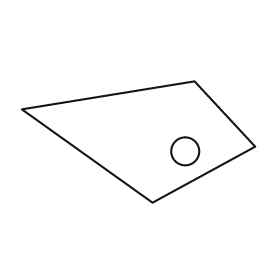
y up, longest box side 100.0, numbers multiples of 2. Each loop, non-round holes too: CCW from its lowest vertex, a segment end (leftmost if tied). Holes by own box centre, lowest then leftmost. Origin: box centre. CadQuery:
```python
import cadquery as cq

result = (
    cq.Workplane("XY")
    .moveTo(6.0, -26.0)
    .lineTo(50.0, -2.0)
    .lineTo(24.0, 26.0)
    .lineTo(-50.0, 14.0)
    .close()
    .moveTo(20.0, -4.0)
    .circle(6.0)
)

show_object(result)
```